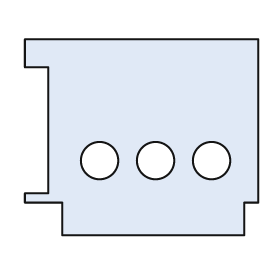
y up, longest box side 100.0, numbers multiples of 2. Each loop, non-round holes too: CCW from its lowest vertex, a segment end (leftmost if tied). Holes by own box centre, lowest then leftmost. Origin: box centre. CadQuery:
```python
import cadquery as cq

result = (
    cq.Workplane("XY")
    .moveTo(-34.0, -42.0)
    .lineTo(44.0, -42.0)
    .lineTo(44.0, -28.0)
    .lineTo(50.0, -28.0)
    .lineTo(50.0, 42.0)
    .lineTo(-50.0, 42.0)
    .lineTo(-50.0, 30.0)
    .lineTo(-40.0, 30.0)
    .lineTo(-40.0, -24.0)
    .lineTo(-50.0, -24.0)
    .lineTo(-50.0, -28.0)
    .lineTo(-34.0, -28.0)
    .close()
    .moveTo(-18.0, -10.0)
    .circle(8.0)
    .moveTo(6.0, -10.0)
    .circle(8.0)
    .moveTo(30.0, -10.0)
    .circle(8.0)
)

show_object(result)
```